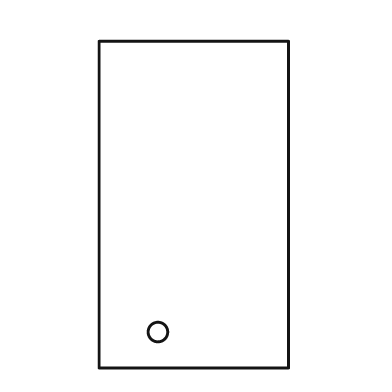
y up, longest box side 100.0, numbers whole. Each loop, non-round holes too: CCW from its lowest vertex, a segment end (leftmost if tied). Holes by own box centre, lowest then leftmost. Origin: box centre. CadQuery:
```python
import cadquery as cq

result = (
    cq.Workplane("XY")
    .moveTo(-29.0, -50.0)
    .lineTo(29.0, -50.0)
    .lineTo(29.0, 50.0)
    .lineTo(-29.0, 50.0)
    .close()
    .moveTo(-11.0, -39.0)
    .circle(3.0)
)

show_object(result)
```